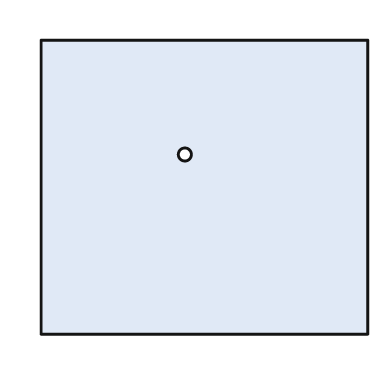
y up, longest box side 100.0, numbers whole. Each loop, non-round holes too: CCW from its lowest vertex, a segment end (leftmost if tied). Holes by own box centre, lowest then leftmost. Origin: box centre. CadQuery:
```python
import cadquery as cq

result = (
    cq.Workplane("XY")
    .moveTo(-50.0, -45.0)
    .lineTo(50.0, -45.0)
    .lineTo(50.0, 45.0)
    .lineTo(-50.0, 45.0)
    .close()
    .moveTo(-6.0, 10.0)
    .circle(2.0)
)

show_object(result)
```